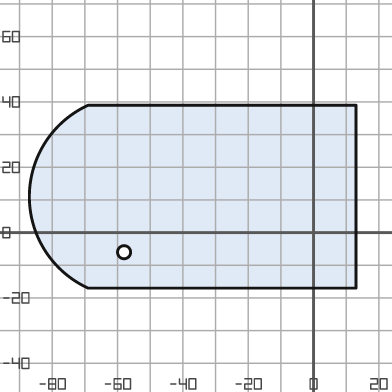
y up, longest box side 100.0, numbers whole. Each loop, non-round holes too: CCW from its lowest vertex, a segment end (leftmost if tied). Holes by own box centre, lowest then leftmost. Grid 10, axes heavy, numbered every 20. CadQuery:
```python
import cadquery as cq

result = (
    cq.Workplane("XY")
    .moveTo(-69.0, -17.0)
    .lineTo(13.0, -17.0)
    .lineTo(13.0, 39.0)
    .lineTo(-69.0, 39.0)
    .threePointArc((-87.0, 11.0), (-69.0, -17.0))
    .close()
    .moveTo(-58.0, -6.0)
    .circle(2.0)
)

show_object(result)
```